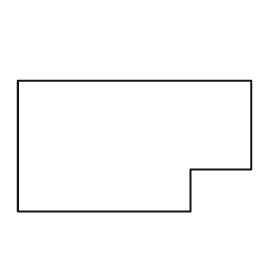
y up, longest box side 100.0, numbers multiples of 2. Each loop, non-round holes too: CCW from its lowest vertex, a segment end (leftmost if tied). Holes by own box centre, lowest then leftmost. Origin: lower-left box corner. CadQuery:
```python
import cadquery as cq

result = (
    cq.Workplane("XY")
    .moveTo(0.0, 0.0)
    .lineTo(74.0, 0.0)
    .lineTo(74.0, 18.0)
    .lineTo(100.0, 18.0)
    .lineTo(100.0, 56.0)
    .lineTo(0.0, 56.0)
    .close()
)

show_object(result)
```